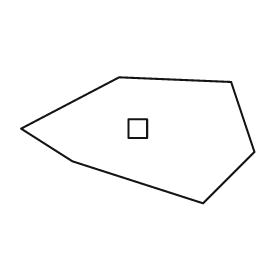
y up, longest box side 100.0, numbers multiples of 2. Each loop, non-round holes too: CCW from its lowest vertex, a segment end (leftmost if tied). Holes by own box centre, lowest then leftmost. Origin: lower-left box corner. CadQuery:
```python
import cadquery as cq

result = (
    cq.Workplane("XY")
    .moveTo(78.0, 0.0)
    .lineTo(100.0, 22.0)
    .lineTo(90.0, 52.0)
    .lineTo(42.0, 54.0)
    .lineTo(0.0, 32.0)
    .lineTo(22.0, 18.0)
    .close()
    .moveTo(46.0, 28.0)
    .lineTo(54.0, 28.0)
    .lineTo(54.0, 36.0)
    .lineTo(46.0, 36.0)
    .close()
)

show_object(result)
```